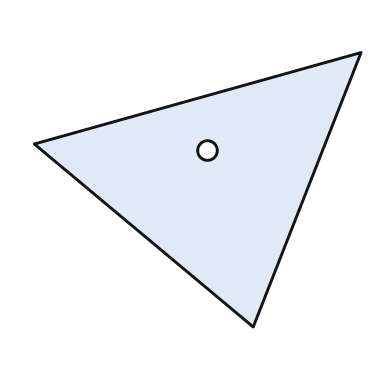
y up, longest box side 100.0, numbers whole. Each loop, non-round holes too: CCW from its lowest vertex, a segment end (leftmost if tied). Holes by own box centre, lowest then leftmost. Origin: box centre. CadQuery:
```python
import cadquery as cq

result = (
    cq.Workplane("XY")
    .moveTo(17.0, -42.0)
    .lineTo(50.0, 42.0)
    .lineTo(-50.0, 14.0)
    .close()
    .moveTo(3.0, 12.0)
    .circle(3.0)
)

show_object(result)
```